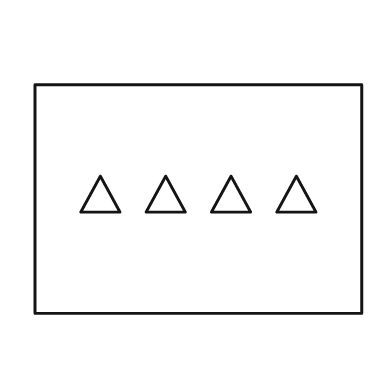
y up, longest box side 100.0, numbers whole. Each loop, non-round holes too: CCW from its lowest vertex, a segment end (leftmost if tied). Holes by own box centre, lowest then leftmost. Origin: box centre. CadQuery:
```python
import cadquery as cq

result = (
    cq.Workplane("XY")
    .moveTo(-50.0, -35.0)
    .lineTo(50.0, -35.0)
    .lineTo(50.0, 35.0)
    .lineTo(-50.0, 35.0)
    .close()
    .moveTo(-36.0, -4.0)
    .lineTo(-24.0, -4.0)
    .lineTo(-30.0, 7.0)
    .close()
    .moveTo(-16.0, -4.0)
    .lineTo(-4.0, -4.0)
    .lineTo(-10.0, 7.0)
    .close()
    .moveTo(4.0, -4.0)
    .lineTo(16.0, -4.0)
    .lineTo(10.0, 7.0)
    .close()
    .moveTo(24.0, -4.0)
    .lineTo(36.0, -4.0)
    .lineTo(30.0, 7.0)
    .close()
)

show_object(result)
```